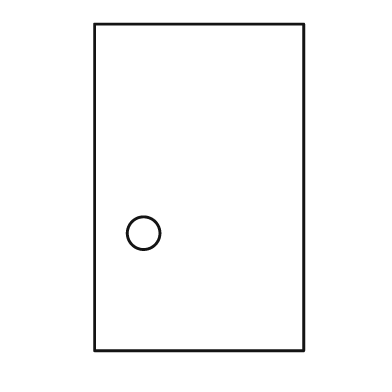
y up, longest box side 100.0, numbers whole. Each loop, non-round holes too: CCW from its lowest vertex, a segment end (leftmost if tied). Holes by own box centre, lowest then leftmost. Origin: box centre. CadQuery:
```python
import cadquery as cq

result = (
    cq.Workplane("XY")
    .moveTo(-32.0, -50.0)
    .lineTo(32.0, -50.0)
    .lineTo(32.0, 50.0)
    .lineTo(-32.0, 50.0)
    .close()
    .moveTo(-17.0, -14.0)
    .circle(5.0)
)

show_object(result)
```